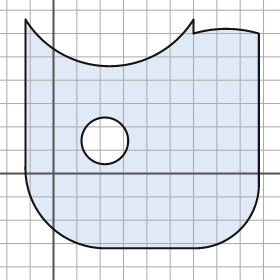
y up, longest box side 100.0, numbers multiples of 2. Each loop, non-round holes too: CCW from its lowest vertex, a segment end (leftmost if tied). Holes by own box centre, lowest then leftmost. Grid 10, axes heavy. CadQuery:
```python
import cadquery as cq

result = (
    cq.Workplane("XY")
    .moveTo(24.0, -32.0)
    .lineTo(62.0, -32.0)
    .threePointArc((80.0, -24.0), (88.0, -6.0))
    .lineTo(88.0, 60.0)
    .threePointArc((74.0, 62.0), (60.0, 60.0))
    .lineTo(60.0, 66.0)
    .threePointArc((24.0, 46.0), (-12.0, 66.0))
    .lineTo(-12.0, 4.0)
    .threePointArc((-2.0, -22.0), (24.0, -32.0))
    .close()
    .moveTo(22.0, 14.0)
    .circle(10.0)
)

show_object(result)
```